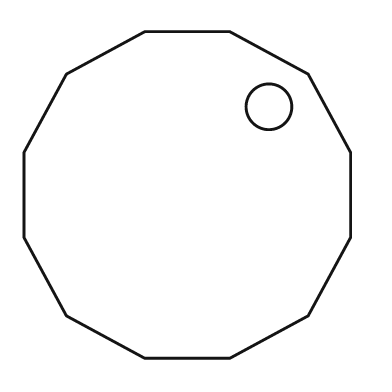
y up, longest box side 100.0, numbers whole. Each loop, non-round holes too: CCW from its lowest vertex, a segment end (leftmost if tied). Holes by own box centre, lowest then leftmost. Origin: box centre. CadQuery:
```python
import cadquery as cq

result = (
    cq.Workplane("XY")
    .moveTo(-13.0, -50.0)
    .lineTo(13.0, -50.0)
    .lineTo(37.0, -37.0)
    .lineTo(50.0, -13.0)
    .lineTo(50.0, 13.0)
    .lineTo(37.0, 37.0)
    .lineTo(13.0, 50.0)
    .lineTo(-13.0, 50.0)
    .lineTo(-37.0, 37.0)
    .lineTo(-50.0, 13.0)
    .lineTo(-50.0, -13.0)
    .lineTo(-37.0, -37.0)
    .close()
    .moveTo(25.0, 27.0)
    .circle(7.0)
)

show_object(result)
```